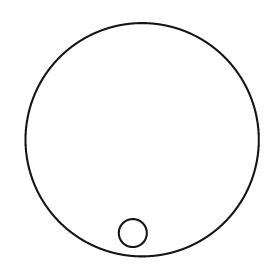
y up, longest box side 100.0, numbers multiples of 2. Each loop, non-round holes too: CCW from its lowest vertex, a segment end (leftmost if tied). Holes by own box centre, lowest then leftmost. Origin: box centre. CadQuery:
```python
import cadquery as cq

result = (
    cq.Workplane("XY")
    .moveTo(0.0, 0.0)
    .circle(50.0)
    .moveTo(-4.0, -40.0)
    .circle(6.0)
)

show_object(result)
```